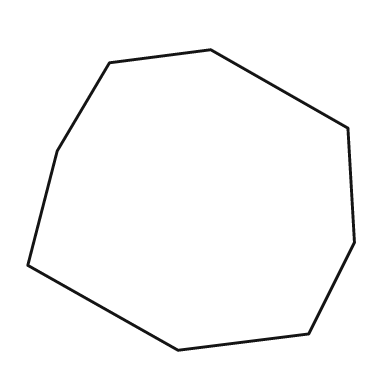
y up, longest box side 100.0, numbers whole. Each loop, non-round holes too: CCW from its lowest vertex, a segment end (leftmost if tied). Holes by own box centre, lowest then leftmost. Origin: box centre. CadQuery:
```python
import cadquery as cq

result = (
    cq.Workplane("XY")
    .moveTo(-4.0, -46.0)
    .lineTo(36.0, -41.0)
    .lineTo(50.0, -13.0)
    .lineTo(48.0, 22.0)
    .lineTo(6.0, 46.0)
    .lineTo(-25.0, 42.0)
    .lineTo(-41.0, 15.0)
    .lineTo(-50.0, -20.0)
    .close()
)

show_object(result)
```